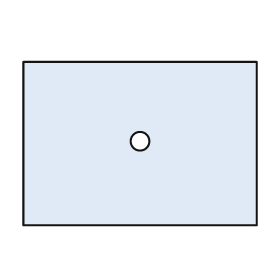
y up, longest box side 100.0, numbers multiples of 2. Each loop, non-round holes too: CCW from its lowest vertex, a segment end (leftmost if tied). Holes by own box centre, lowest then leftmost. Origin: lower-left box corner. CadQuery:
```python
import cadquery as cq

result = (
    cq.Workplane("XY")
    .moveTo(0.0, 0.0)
    .lineTo(100.0, 0.0)
    .lineTo(100.0, 70.0)
    .lineTo(0.0, 70.0)
    .close()
    .moveTo(50.0, 36.0)
    .circle(4.0)
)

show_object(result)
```